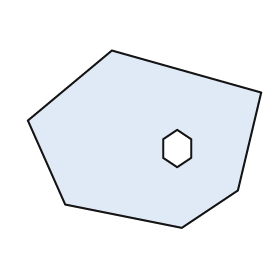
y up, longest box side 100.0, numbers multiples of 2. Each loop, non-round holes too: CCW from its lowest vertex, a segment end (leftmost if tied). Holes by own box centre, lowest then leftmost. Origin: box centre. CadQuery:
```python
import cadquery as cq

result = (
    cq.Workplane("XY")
    .moveTo(16.0, -38.0)
    .lineTo(40.0, -22.0)
    .lineTo(50.0, 20.0)
    .lineTo(-14.0, 38.0)
    .lineTo(-50.0, 8.0)
    .lineTo(-34.0, -28.0)
    .close()
    .moveTo(14.0, -12.0)
    .lineTo(20.0, -8.0)
    .lineTo(20.0, 0.0)
    .lineTo(14.0, 4.0)
    .lineTo(8.0, 0.0)
    .lineTo(8.0, -8.0)
    .close()
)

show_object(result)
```